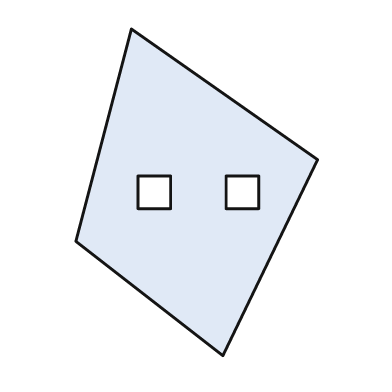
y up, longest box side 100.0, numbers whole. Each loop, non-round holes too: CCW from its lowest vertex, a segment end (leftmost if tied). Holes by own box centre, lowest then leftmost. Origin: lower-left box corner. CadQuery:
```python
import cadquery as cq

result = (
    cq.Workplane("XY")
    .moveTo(45.0, 0.0)
    .lineTo(74.0, 60.0)
    .lineTo(17.0, 100.0)
    .lineTo(0.0, 35.0)
    .close()
    .moveTo(19.0, 45.0)
    .lineTo(29.0, 45.0)
    .lineTo(29.0, 55.0)
    .lineTo(19.0, 55.0)
    .close()
    .moveTo(46.0, 45.0)
    .lineTo(56.0, 45.0)
    .lineTo(56.0, 55.0)
    .lineTo(46.0, 55.0)
    .close()
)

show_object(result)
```